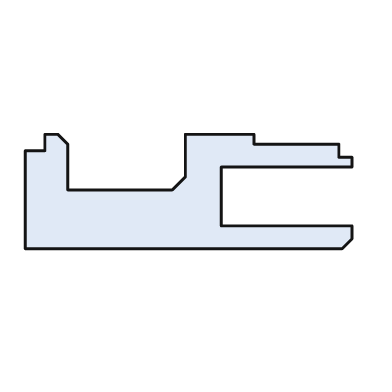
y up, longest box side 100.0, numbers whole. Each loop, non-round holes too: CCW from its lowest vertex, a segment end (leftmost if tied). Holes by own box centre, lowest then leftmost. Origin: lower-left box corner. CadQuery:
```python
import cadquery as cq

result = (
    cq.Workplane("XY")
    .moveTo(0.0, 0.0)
    .lineTo(97.0, 0.0)
    .lineTo(100.0, 3.0)
    .lineTo(100.0, 7.0)
    .lineTo(60.0, 7.0)
    .lineTo(60.0, 25.0)
    .lineTo(100.0, 25.0)
    .lineTo(100.0, 28.0)
    .lineTo(96.0, 28.0)
    .lineTo(96.0, 32.0)
    .lineTo(70.0, 32.0)
    .lineTo(70.0, 35.0)
    .lineTo(49.0, 35.0)
    .lineTo(49.0, 22.0)
    .lineTo(45.0, 18.0)
    .lineTo(13.0, 18.0)
    .lineTo(13.0, 32.0)
    .lineTo(10.0, 35.0)
    .lineTo(6.0, 35.0)
    .lineTo(6.0, 30.0)
    .lineTo(0.0, 30.0)
    .close()
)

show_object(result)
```